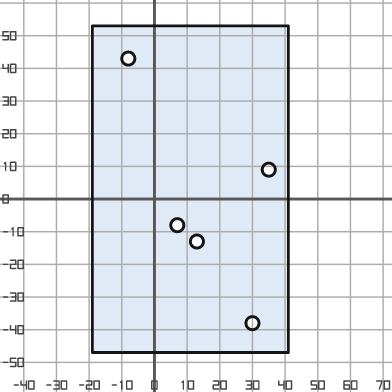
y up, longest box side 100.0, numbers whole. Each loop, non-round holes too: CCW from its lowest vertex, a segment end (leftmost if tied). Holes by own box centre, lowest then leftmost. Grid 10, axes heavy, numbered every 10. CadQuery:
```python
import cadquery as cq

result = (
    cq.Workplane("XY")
    .moveTo(-19.0, -47.0)
    .lineTo(41.0, -47.0)
    .lineTo(41.0, 53.0)
    .lineTo(-19.0, 53.0)
    .close()
    .moveTo(30.0, -38.0)
    .circle(2.0)
    .moveTo(13.0, -13.0)
    .circle(2.0)
    .moveTo(7.0, -8.0)
    .circle(2.0)
    .moveTo(35.0, 9.0)
    .circle(2.0)
    .moveTo(-8.0, 43.0)
    .circle(2.0)
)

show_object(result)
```